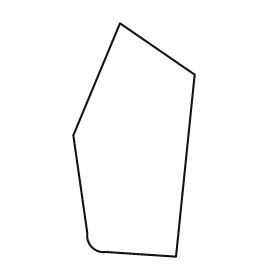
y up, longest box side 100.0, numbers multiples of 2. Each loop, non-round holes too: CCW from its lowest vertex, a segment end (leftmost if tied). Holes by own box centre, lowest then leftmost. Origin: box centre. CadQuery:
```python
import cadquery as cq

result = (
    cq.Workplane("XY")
    .moveTo(18.0, -50.0)
    .lineTo(26.0, 28.0)
    .lineTo(-6.0, 50.0)
    .lineTo(-26.0, 2.0)
    .lineTo(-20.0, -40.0)
    .threePointArc((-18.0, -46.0), (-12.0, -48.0))
    .close()
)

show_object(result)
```